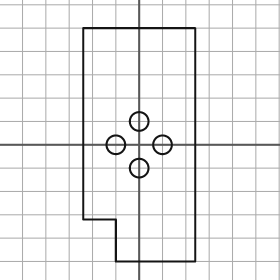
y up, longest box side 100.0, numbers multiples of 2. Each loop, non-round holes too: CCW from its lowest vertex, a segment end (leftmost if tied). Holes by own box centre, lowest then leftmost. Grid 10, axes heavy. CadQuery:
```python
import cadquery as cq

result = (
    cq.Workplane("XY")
    .moveTo(-10.0, -50.0)
    .lineTo(24.0, -50.0)
    .lineTo(24.0, 50.0)
    .lineTo(-24.0, 50.0)
    .lineTo(-24.0, -32.0)
    .lineTo(-10.0, -32.0)
    .close()
    .moveTo(0.0, -10.0)
    .circle(4.0)
    .moveTo(-10.0, 0.0)
    .circle(4.0)
    .moveTo(10.0, 0.0)
    .circle(4.0)
    .moveTo(0.0, 10.0)
    .circle(4.0)
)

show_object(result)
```